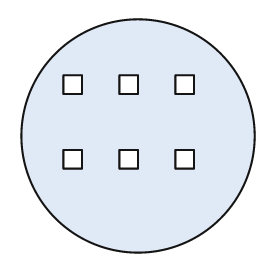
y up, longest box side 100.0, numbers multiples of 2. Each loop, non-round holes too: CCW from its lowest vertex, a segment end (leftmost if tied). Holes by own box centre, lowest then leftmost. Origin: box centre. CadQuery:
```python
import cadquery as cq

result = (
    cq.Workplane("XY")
    .moveTo(0.0, 0.0)
    .circle(50.0)
    .moveTo(-32.0, -14.0)
    .lineTo(-24.0, -14.0)
    .lineTo(-24.0, -6.0)
    .lineTo(-32.0, -6.0)
    .close()
    .moveTo(-8.0, -14.0)
    .lineTo(0.0, -14.0)
    .lineTo(0.0, -6.0)
    .lineTo(-8.0, -6.0)
    .close()
    .moveTo(16.0, -14.0)
    .lineTo(24.0, -14.0)
    .lineTo(24.0, -6.0)
    .lineTo(16.0, -6.0)
    .close()
    .moveTo(-32.0, 18.0)
    .lineTo(-24.0, 18.0)
    .lineTo(-24.0, 26.0)
    .lineTo(-32.0, 26.0)
    .close()
    .moveTo(-8.0, 18.0)
    .lineTo(0.0, 18.0)
    .lineTo(0.0, 26.0)
    .lineTo(-8.0, 26.0)
    .close()
    .moveTo(16.0, 18.0)
    .lineTo(24.0, 18.0)
    .lineTo(24.0, 26.0)
    .lineTo(16.0, 26.0)
    .close()
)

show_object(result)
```